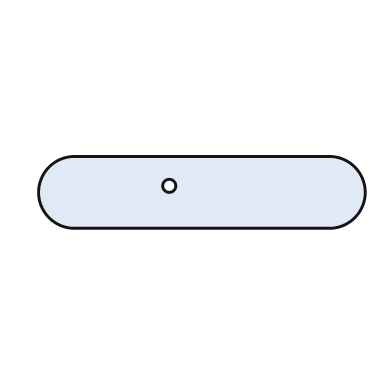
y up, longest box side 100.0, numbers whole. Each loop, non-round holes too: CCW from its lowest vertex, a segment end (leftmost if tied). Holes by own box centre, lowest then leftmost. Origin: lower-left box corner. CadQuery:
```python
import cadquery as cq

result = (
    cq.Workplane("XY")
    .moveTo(11.0, 0.0)
    .lineTo(89.0, 0.0)
    .threePointArc((100.0, 11.0), (89.0, 22.0))
    .lineTo(11.0, 22.0)
    .threePointArc((0.0, 11.0), (11.0, 0.0))
    .close()
    .moveTo(40.0, 13.0)
    .circle(2.0)
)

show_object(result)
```